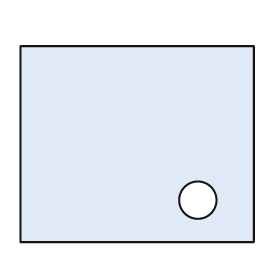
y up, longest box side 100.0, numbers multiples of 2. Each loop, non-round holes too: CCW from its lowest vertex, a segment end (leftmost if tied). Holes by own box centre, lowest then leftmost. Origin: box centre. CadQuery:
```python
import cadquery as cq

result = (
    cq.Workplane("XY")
    .moveTo(-50.0, -42.0)
    .lineTo(50.0, -42.0)
    .lineTo(50.0, 42.0)
    .lineTo(-50.0, 42.0)
    .close()
    .moveTo(26.0, -24.0)
    .circle(8.0)
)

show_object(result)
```